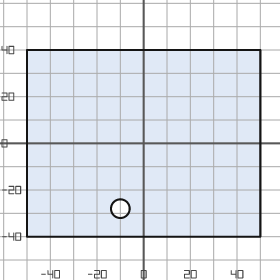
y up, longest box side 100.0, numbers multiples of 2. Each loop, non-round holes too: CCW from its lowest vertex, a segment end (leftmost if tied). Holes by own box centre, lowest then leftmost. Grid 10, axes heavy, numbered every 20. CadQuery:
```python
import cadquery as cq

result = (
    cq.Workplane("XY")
    .moveTo(-50.0, -40.0)
    .lineTo(50.0, -40.0)
    .lineTo(50.0, 40.0)
    .lineTo(-50.0, 40.0)
    .close()
    .moveTo(-10.0, -28.0)
    .circle(4.0)
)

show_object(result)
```